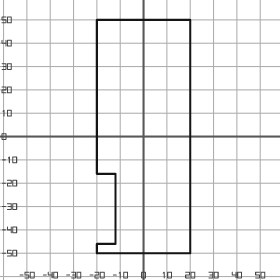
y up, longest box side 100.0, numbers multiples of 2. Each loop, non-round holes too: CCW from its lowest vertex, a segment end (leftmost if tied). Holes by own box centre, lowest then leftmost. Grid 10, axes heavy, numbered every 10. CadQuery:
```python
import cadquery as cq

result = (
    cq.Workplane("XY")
    .moveTo(-20.0, -50.0)
    .lineTo(20.0, -50.0)
    .lineTo(20.0, 50.0)
    .lineTo(-20.0, 50.0)
    .lineTo(-20.0, -16.0)
    .lineTo(-12.0, -16.0)
    .lineTo(-12.0, -46.0)
    .lineTo(-20.0, -46.0)
    .close()
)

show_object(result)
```